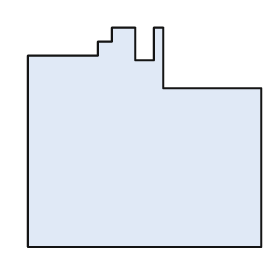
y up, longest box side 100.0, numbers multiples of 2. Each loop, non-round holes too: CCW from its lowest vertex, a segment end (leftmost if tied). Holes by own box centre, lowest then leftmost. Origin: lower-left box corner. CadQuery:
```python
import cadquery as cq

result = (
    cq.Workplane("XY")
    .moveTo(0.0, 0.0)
    .lineTo(100.0, 0.0)
    .lineTo(100.0, 68.0)
    .lineTo(58.0, 68.0)
    .lineTo(58.0, 94.0)
    .lineTo(54.0, 94.0)
    .lineTo(54.0, 80.0)
    .lineTo(46.0, 80.0)
    .lineTo(46.0, 94.0)
    .lineTo(36.0, 94.0)
    .lineTo(36.0, 88.0)
    .lineTo(30.0, 88.0)
    .lineTo(30.0, 82.0)
    .lineTo(0.0, 82.0)
    .close()
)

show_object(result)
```